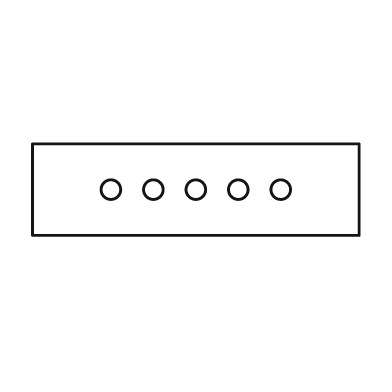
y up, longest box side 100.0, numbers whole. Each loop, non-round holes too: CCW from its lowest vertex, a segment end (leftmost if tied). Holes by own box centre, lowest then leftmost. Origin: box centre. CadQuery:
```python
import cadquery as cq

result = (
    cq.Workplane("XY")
    .moveTo(-50.0, -14.0)
    .lineTo(50.0, -14.0)
    .lineTo(50.0, 14.0)
    .lineTo(-50.0, 14.0)
    .close()
    .moveTo(-26.0, 0.0)
    .circle(3.0)
    .moveTo(-13.0, 0.0)
    .circle(3.0)
    .moveTo(0.0, 0.0)
    .circle(3.0)
    .moveTo(13.0, 0.0)
    .circle(3.0)
    .moveTo(26.0, 0.0)
    .circle(3.0)
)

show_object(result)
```